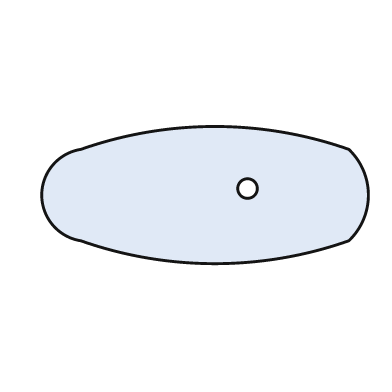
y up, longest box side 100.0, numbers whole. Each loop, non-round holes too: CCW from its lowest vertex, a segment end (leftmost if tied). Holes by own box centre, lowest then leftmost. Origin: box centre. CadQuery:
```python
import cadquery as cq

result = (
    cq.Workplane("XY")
    .moveTo(-38.0, -14.0)
    .threePointArc((3.0, -21.0), (44.0, -14.0))
    .threePointArc((50.0, 0.0), (44.0, 14.0))
    .threePointArc((3.0, 21.0), (-38.0, 14.0))
    .threePointArc((-50.0, 0.0), (-38.0, -14.0))
    .close()
    .moveTo(13.0, 2.0)
    .circle(3.0)
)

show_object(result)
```